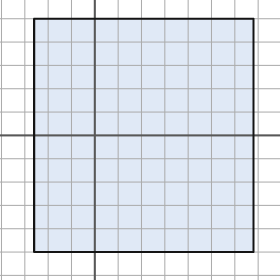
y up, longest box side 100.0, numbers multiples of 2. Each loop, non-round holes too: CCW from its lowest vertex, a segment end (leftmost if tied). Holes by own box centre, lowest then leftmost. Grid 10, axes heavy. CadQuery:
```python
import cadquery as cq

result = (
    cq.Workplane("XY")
    .moveTo(-26.0, -50.0)
    .lineTo(68.0, -50.0)
    .lineTo(68.0, 50.0)
    .lineTo(-26.0, 50.0)
    .close()
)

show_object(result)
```